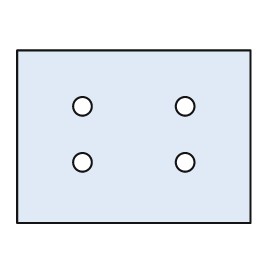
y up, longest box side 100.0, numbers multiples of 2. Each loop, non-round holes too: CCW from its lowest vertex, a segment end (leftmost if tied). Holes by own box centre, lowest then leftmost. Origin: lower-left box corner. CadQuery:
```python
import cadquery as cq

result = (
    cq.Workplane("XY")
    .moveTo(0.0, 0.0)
    .lineTo(100.0, 0.0)
    .lineTo(100.0, 74.0)
    .lineTo(0.0, 74.0)
    .close()
    .moveTo(28.0, 26.0)
    .circle(4.0)
    .moveTo(72.0, 26.0)
    .circle(4.0)
    .moveTo(28.0, 50.0)
    .circle(4.0)
    .moveTo(72.0, 50.0)
    .circle(4.0)
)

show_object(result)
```